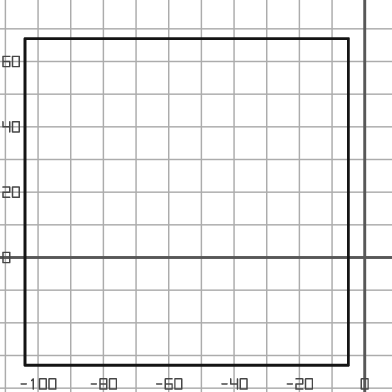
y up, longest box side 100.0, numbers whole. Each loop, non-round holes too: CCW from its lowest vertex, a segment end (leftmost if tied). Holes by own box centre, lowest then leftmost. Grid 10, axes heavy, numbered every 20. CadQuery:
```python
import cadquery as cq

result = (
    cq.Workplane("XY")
    .moveTo(-104.0, -33.0)
    .lineTo(-5.0, -33.0)
    .lineTo(-5.0, 67.0)
    .lineTo(-104.0, 67.0)
    .close()
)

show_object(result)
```